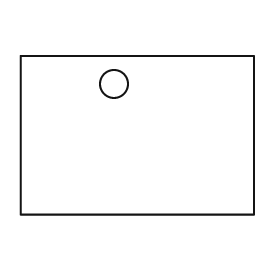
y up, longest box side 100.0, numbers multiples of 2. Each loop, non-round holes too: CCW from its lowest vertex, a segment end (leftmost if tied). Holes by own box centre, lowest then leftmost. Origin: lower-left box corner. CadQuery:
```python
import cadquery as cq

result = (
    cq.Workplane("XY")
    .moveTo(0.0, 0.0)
    .lineTo(100.0, 0.0)
    .lineTo(100.0, 68.0)
    .lineTo(0.0, 68.0)
    .close()
    .moveTo(40.0, 56.0)
    .circle(6.0)
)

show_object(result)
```